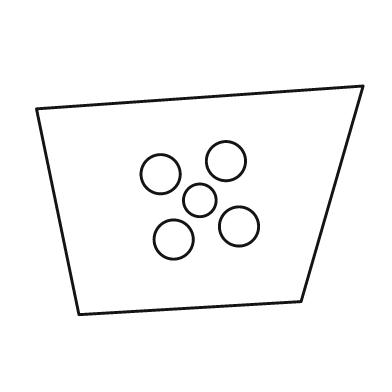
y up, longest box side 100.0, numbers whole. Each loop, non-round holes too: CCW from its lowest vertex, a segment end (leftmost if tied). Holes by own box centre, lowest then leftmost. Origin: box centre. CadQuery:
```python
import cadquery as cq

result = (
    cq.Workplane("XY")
    .moveTo(-37.0, -35.0)
    .lineTo(31.0, -31.0)
    .lineTo(50.0, 35.0)
    .lineTo(-50.0, 28.0)
    .close()
    .moveTo(-8.0, -12.0)
    .circle(6.0)
    .moveTo(12.0, -8.0)
    .circle(6.0)
    .moveTo(0.0, 0.0)
    .circle(5.0)
    .moveTo(-12.0, 8.0)
    .circle(6.0)
    .moveTo(8.0, 12.0)
    .circle(6.0)
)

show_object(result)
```